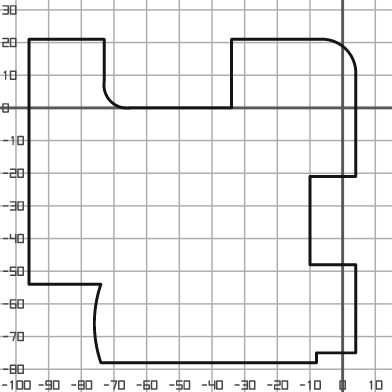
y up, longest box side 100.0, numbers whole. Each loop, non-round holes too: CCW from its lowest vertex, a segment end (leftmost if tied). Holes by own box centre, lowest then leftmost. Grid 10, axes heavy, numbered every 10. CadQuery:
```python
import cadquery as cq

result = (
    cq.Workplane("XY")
    .moveTo(-74.0, -78.0)
    .lineTo(-8.0, -78.0)
    .lineTo(-8.0, -75.0)
    .lineTo(4.0, -75.0)
    .lineTo(4.0, -48.0)
    .lineTo(-10.0, -48.0)
    .lineTo(-10.0, -21.0)
    .lineTo(4.0, -21.0)
    .lineTo(4.0, 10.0)
    .threePointArc((1.0, 18.0), (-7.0, 21.0))
    .lineTo(-34.0, 21.0)
    .lineTo(-34.0, 0.0)
    .lineTo(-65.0, 0.0)
    .threePointArc((-71.0, 2.0), (-73.0, 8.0))
    .lineTo(-73.0, 21.0)
    .lineTo(-96.0, 21.0)
    .lineTo(-96.0, -54.0)
    .lineTo(-74.0, -54.0)
    .threePointArc((-76.0, -66.0), (-74.0, -78.0))
    .close()
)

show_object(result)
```